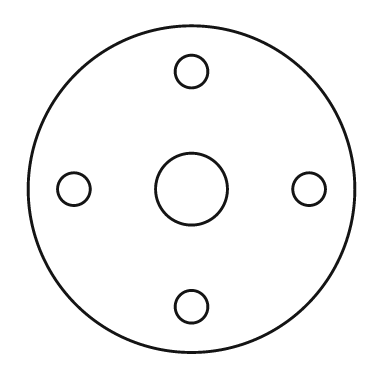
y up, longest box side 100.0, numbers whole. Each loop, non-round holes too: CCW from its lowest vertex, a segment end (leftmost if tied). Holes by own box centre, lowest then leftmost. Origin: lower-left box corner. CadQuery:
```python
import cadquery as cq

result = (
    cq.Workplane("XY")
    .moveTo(50.0, 50.0)
    .circle(50.0)
    .moveTo(50.0, 14.0)
    .circle(5.0)
    .moveTo(14.0, 50.0)
    .circle(5.0)
    .moveTo(50.0, 50.0)
    .circle(11.0)
    .moveTo(86.0, 50.0)
    .circle(5.0)
    .moveTo(50.0, 86.0)
    .circle(5.0)
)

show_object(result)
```